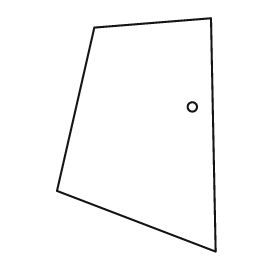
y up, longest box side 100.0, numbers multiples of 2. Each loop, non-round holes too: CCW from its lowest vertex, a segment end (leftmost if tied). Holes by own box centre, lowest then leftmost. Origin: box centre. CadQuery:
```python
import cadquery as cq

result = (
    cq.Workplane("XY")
    .moveTo(34.0, -50.0)
    .lineTo(32.0, 50.0)
    .lineTo(-18.0, 46.0)
    .lineTo(-34.0, -24.0)
    .close()
    .moveTo(24.0, 12.0)
    .circle(2.0)
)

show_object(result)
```